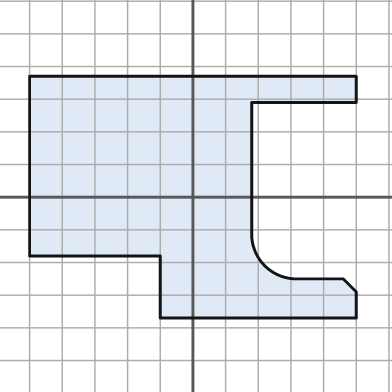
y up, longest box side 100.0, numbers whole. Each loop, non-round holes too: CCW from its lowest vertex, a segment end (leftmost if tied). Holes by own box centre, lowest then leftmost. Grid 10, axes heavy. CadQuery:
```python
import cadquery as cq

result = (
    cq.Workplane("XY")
    .moveTo(-10.0, -37.0)
    .lineTo(50.0, -37.0)
    .lineTo(50.0, -29.0)
    .lineTo(46.0, -25.0)
    .lineTo(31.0, -25.0)
    .threePointArc((22.0, -21.0), (18.0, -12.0))
    .lineTo(18.0, 29.0)
    .lineTo(50.0, 29.0)
    .lineTo(50.0, 37.0)
    .lineTo(-50.0, 37.0)
    .lineTo(-50.0, -18.0)
    .lineTo(-10.0, -18.0)
    .close()
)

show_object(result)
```